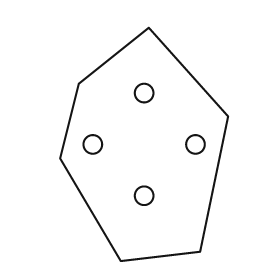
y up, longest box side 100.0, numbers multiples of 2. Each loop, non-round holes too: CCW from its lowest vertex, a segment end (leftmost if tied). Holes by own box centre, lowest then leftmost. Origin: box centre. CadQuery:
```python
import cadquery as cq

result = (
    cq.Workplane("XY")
    .moveTo(-10.0, -50.0)
    .lineTo(24.0, -46.0)
    .lineTo(36.0, 12.0)
    .lineTo(2.0, 50.0)
    .lineTo(-28.0, 26.0)
    .lineTo(-36.0, -6.0)
    .close()
    .moveTo(0.0, -22.0)
    .circle(4.0)
    .moveTo(-22.0, 0.0)
    .circle(4.0)
    .moveTo(22.0, 0.0)
    .circle(4.0)
    .moveTo(0.0, 22.0)
    .circle(4.0)
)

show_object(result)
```